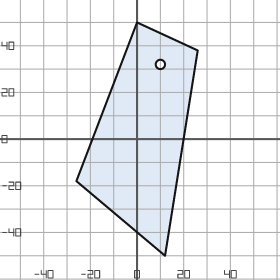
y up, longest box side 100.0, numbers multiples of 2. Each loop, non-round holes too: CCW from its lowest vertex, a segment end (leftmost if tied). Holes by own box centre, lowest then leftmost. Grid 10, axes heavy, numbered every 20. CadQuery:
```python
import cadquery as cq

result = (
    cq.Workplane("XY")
    .moveTo(12.0, -50.0)
    .lineTo(26.0, 38.0)
    .lineTo(0.0, 50.0)
    .lineTo(-26.0, -18.0)
    .close()
    .moveTo(10.0, 32.0)
    .circle(2.0)
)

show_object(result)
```